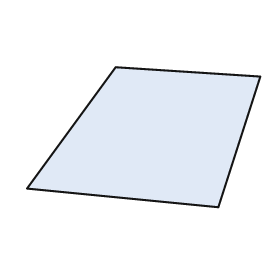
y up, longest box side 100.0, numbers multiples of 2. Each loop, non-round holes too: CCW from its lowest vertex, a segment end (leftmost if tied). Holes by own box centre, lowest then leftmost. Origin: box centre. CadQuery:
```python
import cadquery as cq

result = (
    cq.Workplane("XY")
    .moveTo(32.0, -30.0)
    .lineTo(50.0, 26.0)
    .lineTo(-12.0, 30.0)
    .lineTo(-50.0, -22.0)
    .close()
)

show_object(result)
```